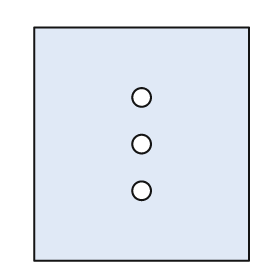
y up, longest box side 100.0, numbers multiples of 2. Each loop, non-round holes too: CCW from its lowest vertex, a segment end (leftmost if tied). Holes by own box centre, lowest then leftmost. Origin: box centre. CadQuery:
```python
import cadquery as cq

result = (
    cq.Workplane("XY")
    .moveTo(-46.0, -50.0)
    .lineTo(46.0, -50.0)
    .lineTo(46.0, 50.0)
    .lineTo(-46.0, 50.0)
    .close()
    .moveTo(0.0, -20.0)
    .circle(4.0)
    .moveTo(0.0, 0.0)
    .circle(4.0)
    .moveTo(0.0, 20.0)
    .circle(4.0)
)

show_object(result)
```